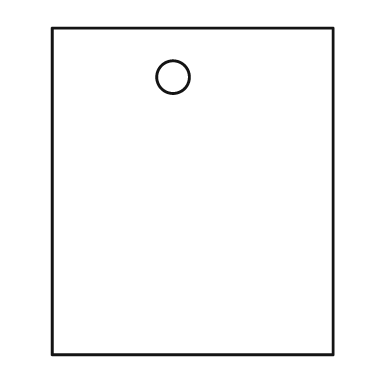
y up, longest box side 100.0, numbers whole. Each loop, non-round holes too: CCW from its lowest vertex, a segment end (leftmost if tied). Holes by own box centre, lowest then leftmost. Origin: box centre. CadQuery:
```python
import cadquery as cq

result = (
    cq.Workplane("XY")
    .moveTo(-43.0, -50.0)
    .lineTo(43.0, -50.0)
    .lineTo(43.0, 50.0)
    .lineTo(-43.0, 50.0)
    .close()
    .moveTo(-6.0, 35.0)
    .circle(5.0)
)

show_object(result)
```